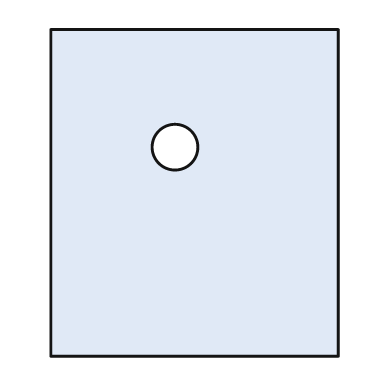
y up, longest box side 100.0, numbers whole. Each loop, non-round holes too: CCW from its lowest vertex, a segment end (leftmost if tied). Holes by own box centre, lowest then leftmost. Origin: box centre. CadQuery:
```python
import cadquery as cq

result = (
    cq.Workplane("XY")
    .moveTo(-44.0, -50.0)
    .lineTo(44.0, -50.0)
    .lineTo(44.0, 50.0)
    .lineTo(-44.0, 50.0)
    .close()
    .moveTo(-6.0, 14.0)
    .circle(7.0)
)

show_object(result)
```